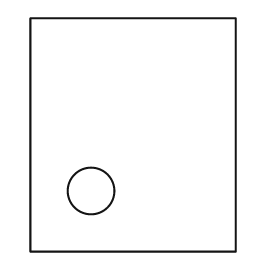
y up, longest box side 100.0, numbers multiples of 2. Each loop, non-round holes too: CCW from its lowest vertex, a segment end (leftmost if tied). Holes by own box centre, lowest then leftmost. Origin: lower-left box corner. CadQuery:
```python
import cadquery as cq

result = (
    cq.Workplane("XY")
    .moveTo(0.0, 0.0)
    .lineTo(88.0, 0.0)
    .lineTo(88.0, 100.0)
    .lineTo(0.0, 100.0)
    .close()
    .moveTo(26.0, 26.0)
    .circle(10.0)
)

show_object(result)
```